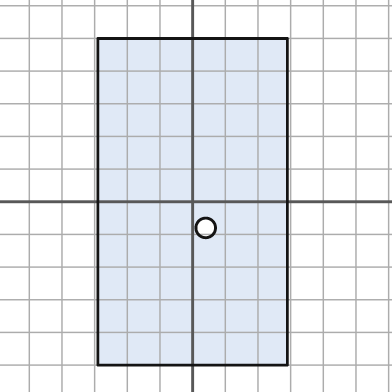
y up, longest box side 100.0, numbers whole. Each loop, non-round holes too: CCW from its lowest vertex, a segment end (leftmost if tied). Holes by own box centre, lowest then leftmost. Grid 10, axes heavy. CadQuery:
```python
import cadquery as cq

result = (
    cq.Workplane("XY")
    .moveTo(-29.0, -50.0)
    .lineTo(29.0, -50.0)
    .lineTo(29.0, 50.0)
    .lineTo(-29.0, 50.0)
    .close()
    .moveTo(4.0, -8.0)
    .circle(3.0)
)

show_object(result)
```